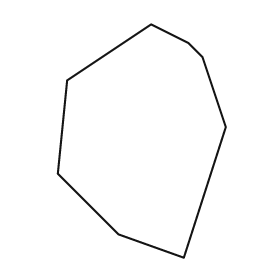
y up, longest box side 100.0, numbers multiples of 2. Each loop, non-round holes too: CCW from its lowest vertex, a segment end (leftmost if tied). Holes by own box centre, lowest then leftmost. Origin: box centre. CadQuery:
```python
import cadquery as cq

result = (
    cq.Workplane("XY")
    .moveTo(18.0, -50.0)
    .lineTo(36.0, 6.0)
    .lineTo(26.0, 36.0)
    .lineTo(20.0, 42.0)
    .lineTo(4.0, 50.0)
    .lineTo(-32.0, 26.0)
    .lineTo(-36.0, -14.0)
    .lineTo(-10.0, -40.0)
    .close()
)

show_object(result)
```